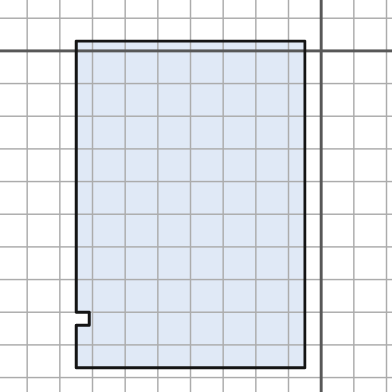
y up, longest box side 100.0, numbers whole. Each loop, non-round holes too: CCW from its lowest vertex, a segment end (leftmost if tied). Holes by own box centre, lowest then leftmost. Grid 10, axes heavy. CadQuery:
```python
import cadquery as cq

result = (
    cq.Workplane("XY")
    .moveTo(-75.0, -97.0)
    .lineTo(-5.0, -97.0)
    .lineTo(-5.0, 3.0)
    .lineTo(-75.0, 3.0)
    .lineTo(-75.0, -80.0)
    .lineTo(-71.0, -80.0)
    .lineTo(-71.0, -84.0)
    .lineTo(-75.0, -84.0)
    .close()
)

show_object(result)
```